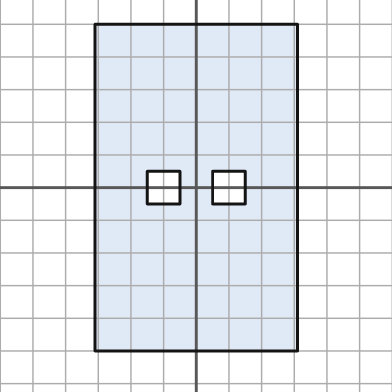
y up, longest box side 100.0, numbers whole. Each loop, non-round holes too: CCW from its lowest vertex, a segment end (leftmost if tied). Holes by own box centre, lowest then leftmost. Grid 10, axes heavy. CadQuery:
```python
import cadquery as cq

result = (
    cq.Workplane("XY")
    .moveTo(-31.0, -50.0)
    .lineTo(31.0, -50.0)
    .lineTo(31.0, 50.0)
    .lineTo(-31.0, 50.0)
    .close()
    .moveTo(-15.0, -5.0)
    .lineTo(-5.0, -5.0)
    .lineTo(-5.0, 5.0)
    .lineTo(-15.0, 5.0)
    .close()
    .moveTo(5.0, -5.0)
    .lineTo(15.0, -5.0)
    .lineTo(15.0, 5.0)
    .lineTo(5.0, 5.0)
    .close()
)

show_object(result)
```